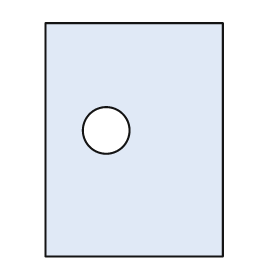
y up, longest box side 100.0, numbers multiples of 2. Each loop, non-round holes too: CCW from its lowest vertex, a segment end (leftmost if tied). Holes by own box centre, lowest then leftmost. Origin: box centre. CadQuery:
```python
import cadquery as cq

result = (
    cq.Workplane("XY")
    .moveTo(-38.0, -50.0)
    .lineTo(38.0, -50.0)
    .lineTo(38.0, 50.0)
    .lineTo(-38.0, 50.0)
    .close()
    .moveTo(-12.0, 4.0)
    .circle(10.0)
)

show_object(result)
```